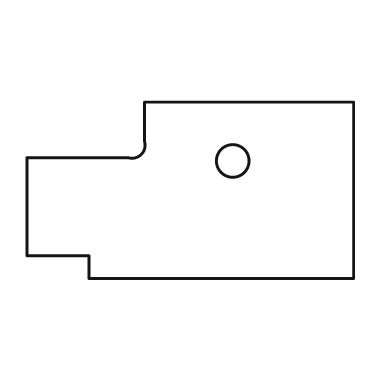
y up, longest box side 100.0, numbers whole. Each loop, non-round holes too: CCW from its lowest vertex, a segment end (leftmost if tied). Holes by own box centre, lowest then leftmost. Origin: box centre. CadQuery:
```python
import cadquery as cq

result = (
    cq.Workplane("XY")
    .moveTo(-31.0, -27.0)
    .lineTo(50.0, -27.0)
    .lineTo(50.0, 27.0)
    .lineTo(-14.0, 27.0)
    .lineTo(-14.0, 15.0)
    .threePointArc((-15.0, 11.0), (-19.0, 10.0))
    .lineTo(-50.0, 10.0)
    .lineTo(-50.0, -20.0)
    .lineTo(-31.0, -20.0)
    .close()
    .moveTo(13.0, 9.0)
    .circle(5.0)
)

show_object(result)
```